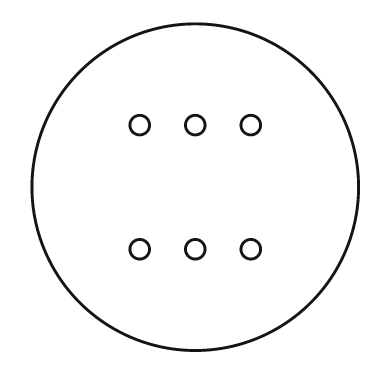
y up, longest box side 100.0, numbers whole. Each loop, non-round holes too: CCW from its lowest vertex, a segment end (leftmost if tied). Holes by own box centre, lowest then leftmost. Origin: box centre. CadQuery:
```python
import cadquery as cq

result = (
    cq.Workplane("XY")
    .moveTo(0.0, 0.0)
    .circle(50.0)
    .moveTo(-17.0, -19.0)
    .circle(3.0)
    .moveTo(0.0, -19.0)
    .circle(3.0)
    .moveTo(17.0, -19.0)
    .circle(3.0)
    .moveTo(-17.0, 19.0)
    .circle(3.0)
    .moveTo(0.0, 19.0)
    .circle(3.0)
    .moveTo(17.0, 19.0)
    .circle(3.0)
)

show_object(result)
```